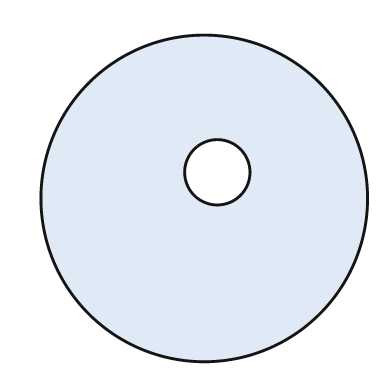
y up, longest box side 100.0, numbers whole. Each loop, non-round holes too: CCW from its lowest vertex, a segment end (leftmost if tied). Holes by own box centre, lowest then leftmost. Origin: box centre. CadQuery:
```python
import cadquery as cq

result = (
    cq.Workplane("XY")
    .moveTo(0.0, 0.0)
    .circle(50.0)
    .moveTo(4.0, 8.0)
    .circle(10.0)
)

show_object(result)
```